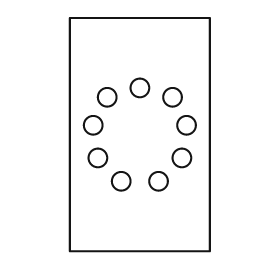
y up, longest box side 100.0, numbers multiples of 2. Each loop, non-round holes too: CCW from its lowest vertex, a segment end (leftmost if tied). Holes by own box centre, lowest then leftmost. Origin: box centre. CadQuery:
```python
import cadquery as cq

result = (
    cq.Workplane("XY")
    .moveTo(-30.0, -50.0)
    .lineTo(30.0, -50.0)
    .lineTo(30.0, 50.0)
    .lineTo(-30.0, 50.0)
    .close()
    .moveTo(-8.0, -20.0)
    .circle(4.0)
    .moveTo(8.0, -20.0)
    .circle(4.0)
    .moveTo(-18.0, -10.0)
    .circle(4.0)
    .moveTo(18.0, -10.0)
    .circle(4.0)
    .moveTo(-20.0, 4.0)
    .circle(4.0)
    .moveTo(20.0, 4.0)
    .circle(4.0)
    .moveTo(-14.0, 16.0)
    .circle(4.0)
    .moveTo(14.0, 16.0)
    .circle(4.0)
    .moveTo(0.0, 20.0)
    .circle(4.0)
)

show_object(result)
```